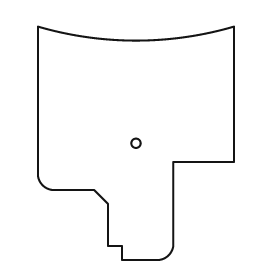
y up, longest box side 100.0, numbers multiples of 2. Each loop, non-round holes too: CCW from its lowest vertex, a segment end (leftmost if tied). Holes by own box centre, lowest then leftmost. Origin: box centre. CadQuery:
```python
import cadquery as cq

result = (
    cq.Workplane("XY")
    .moveTo(-6.0, -50.0)
    .lineTo(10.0, -50.0)
    .threePointArc((14.0, -48.0), (16.0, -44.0))
    .lineTo(16.0, -8.0)
    .lineTo(42.0, -8.0)
    .lineTo(42.0, 50.0)
    .threePointArc((0.0, 44.0), (-42.0, 50.0))
    .lineTo(-42.0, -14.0)
    .threePointArc((-40.0, -18.0), (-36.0, -20.0))
    .lineTo(-18.0, -20.0)
    .lineTo(-12.0, -26.0)
    .lineTo(-12.0, -44.0)
    .lineTo(-6.0, -44.0)
    .close()
    .moveTo(0.0, 0.0)
    .circle(2.0)
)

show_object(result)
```